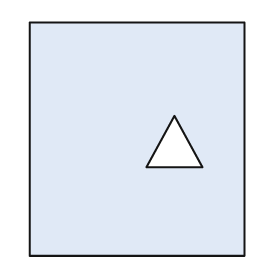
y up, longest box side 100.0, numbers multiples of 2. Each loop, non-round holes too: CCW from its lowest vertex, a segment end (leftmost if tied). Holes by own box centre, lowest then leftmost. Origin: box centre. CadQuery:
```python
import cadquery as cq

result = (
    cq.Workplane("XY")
    .moveTo(-46.0, -50.0)
    .lineTo(46.0, -50.0)
    .lineTo(46.0, 50.0)
    .lineTo(-46.0, 50.0)
    .close()
    .moveTo(4.0, -12.0)
    .lineTo(28.0, -12.0)
    .lineTo(16.0, 10.0)
    .close()
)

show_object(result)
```